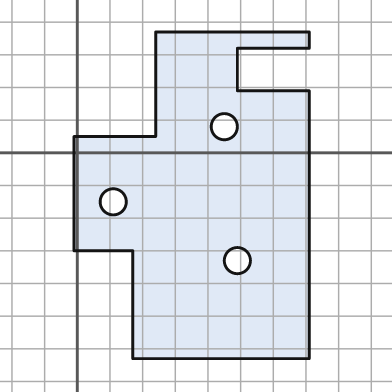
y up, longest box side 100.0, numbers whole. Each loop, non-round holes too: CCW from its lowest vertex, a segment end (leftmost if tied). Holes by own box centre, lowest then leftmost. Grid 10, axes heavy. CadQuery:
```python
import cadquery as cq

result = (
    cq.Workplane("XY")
    .moveTo(17.0, -63.0)
    .lineTo(71.0, -63.0)
    .lineTo(71.0, 19.0)
    .lineTo(49.0, 19.0)
    .lineTo(49.0, 32.0)
    .lineTo(71.0, 32.0)
    .lineTo(71.0, 37.0)
    .lineTo(24.0, 37.0)
    .lineTo(24.0, 5.0)
    .lineTo(-1.0, 5.0)
    .lineTo(-1.0, -30.0)
    .lineTo(17.0, -30.0)
    .close()
    .moveTo(49.0, -33.0)
    .circle(4.0)
    .moveTo(11.0, -15.0)
    .circle(4.0)
    .moveTo(45.0, 8.0)
    .circle(4.0)
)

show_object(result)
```